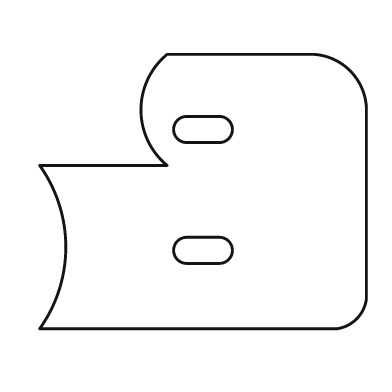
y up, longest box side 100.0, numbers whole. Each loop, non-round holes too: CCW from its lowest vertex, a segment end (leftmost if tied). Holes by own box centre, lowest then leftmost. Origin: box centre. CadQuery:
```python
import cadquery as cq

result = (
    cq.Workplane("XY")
    .moveTo(-50.0, -42.0)
    .lineTo(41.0, -42.0)
    .threePointArc((47.0, -39.0), (50.0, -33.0))
    .lineTo(50.0, 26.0)
    .threePointArc((45.0, 37.0), (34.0, 42.0))
    .lineTo(-11.0, 42.0)
    .threePointArc((-19.0, 25.0), (-11.0, 8.0))
    .lineTo(-50.0, 8.0)
    .threePointArc((-42.0, -17.0), (-50.0, -42.0))
    .close()
    .moveTo(-5.0, -22.0)
    .lineTo(5.0, -22.0)
    .threePointArc((9.0, -18.0), (5.0, -14.0))
    .lineTo(-5.0, -14.0)
    .threePointArc((-9.0, -18.0), (-5.0, -22.0))
    .close()
    .moveTo(-5.0, 15.0)
    .lineTo(5.0, 15.0)
    .threePointArc((9.0, 19.0), (5.0, 23.0))
    .lineTo(-5.0, 23.0)
    .threePointArc((-9.0, 19.0), (-5.0, 15.0))
    .close()
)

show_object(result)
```